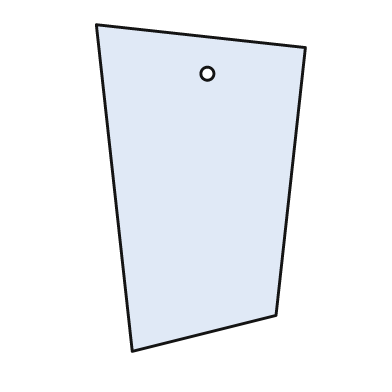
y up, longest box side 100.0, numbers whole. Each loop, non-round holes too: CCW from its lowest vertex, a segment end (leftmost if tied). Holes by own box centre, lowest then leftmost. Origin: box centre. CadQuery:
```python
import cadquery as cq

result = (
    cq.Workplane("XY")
    .moveTo(-21.0, -50.0)
    .lineTo(23.0, -39.0)
    .lineTo(32.0, 43.0)
    .lineTo(-32.0, 50.0)
    .close()
    .moveTo(2.0, 35.0)
    .circle(2.0)
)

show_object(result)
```